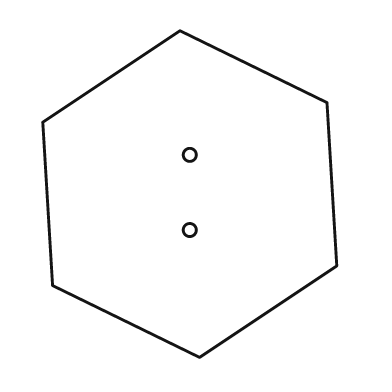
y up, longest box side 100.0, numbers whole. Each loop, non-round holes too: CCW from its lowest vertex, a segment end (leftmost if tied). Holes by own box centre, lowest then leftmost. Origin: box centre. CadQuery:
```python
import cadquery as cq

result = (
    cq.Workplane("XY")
    .moveTo(3.0, -50.0)
    .lineTo(45.0, -22.0)
    .lineTo(42.0, 28.0)
    .lineTo(-3.0, 50.0)
    .lineTo(-45.0, 22.0)
    .lineTo(-42.0, -28.0)
    .close()
    .moveTo(0.0, -11.0)
    .circle(2.0)
    .moveTo(0.0, 12.0)
    .circle(2.0)
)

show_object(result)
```